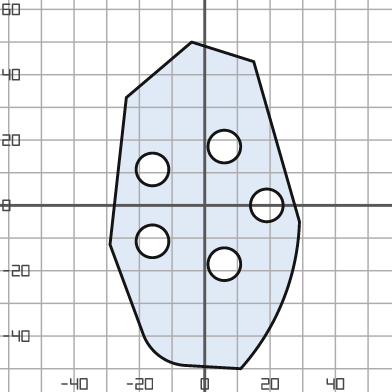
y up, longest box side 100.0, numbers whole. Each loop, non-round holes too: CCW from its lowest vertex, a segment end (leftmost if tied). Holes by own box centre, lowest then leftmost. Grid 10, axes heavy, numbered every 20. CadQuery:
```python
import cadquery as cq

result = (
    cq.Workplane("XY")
    .moveTo(11.0, -50.0)
    .threePointArc((24.0, -29.0), (29.0, -5.0))
    .lineTo(15.0, 44.0)
    .lineTo(-4.0, 50.0)
    .lineTo(-24.0, 33.0)
    .lineTo(-29.0, -12.0)
    .lineTo(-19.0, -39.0)
    .threePointArc((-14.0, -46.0), (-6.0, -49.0))
    .close()
    .moveTo(6.0, -18.0)
    .circle(5.0)
    .moveTo(-16.0, -11.0)
    .circle(5.0)
    .moveTo(19.0, 0.0)
    .circle(5.0)
    .moveTo(-16.0, 11.0)
    .circle(5.0)
    .moveTo(6.0, 18.0)
    .circle(5.0)
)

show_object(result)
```